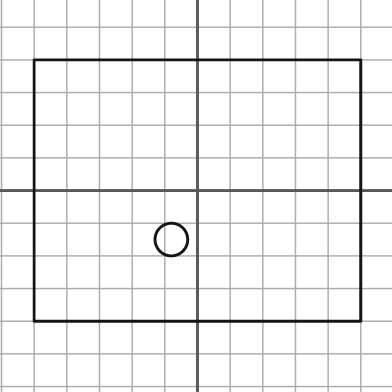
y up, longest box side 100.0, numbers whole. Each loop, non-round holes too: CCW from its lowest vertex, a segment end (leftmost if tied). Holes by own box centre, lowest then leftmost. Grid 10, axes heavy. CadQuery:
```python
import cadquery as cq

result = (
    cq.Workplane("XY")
    .moveTo(-50.0, -40.0)
    .lineTo(50.0, -40.0)
    .lineTo(50.0, 40.0)
    .lineTo(-50.0, 40.0)
    .close()
    .moveTo(-8.0, -15.0)
    .circle(5.0)
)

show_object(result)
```